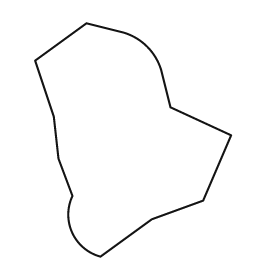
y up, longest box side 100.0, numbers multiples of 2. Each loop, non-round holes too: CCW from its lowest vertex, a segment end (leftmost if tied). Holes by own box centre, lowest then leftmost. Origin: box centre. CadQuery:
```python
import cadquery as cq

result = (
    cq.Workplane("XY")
    .moveTo(-14.0, -50.0)
    .lineTo(8.0, -34.0)
    .lineTo(30.0, -26.0)
    .lineTo(42.0, 2.0)
    .lineTo(16.0, 14.0)
    .lineTo(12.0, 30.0)
    .threePointArc((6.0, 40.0), (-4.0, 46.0))
    .lineTo(-20.0, 50.0)
    .lineTo(-42.0, 34.0)
    .lineTo(-34.0, 10.0)
    .lineTo(-32.0, -8.0)
    .lineTo(-26.0, -24.0)
    .threePointArc((-26.0, -40.0), (-14.0, -50.0))
    .close()
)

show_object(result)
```